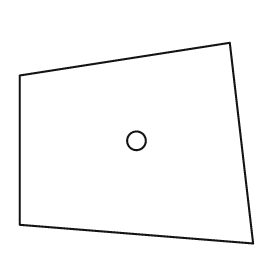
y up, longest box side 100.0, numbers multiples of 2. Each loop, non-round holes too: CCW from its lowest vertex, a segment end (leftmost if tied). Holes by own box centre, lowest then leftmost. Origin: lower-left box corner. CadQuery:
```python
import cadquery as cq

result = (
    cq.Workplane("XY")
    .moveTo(100.0, 0.0)
    .lineTo(90.0, 86.0)
    .lineTo(0.0, 72.0)
    .lineTo(0.0, 8.0)
    .close()
    .moveTo(50.0, 44.0)
    .circle(4.0)
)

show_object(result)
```